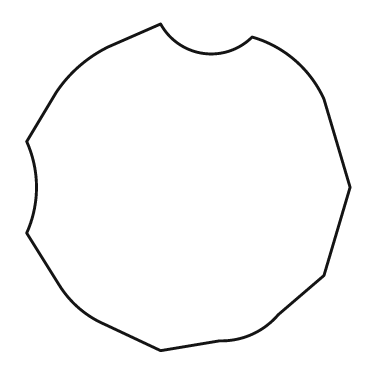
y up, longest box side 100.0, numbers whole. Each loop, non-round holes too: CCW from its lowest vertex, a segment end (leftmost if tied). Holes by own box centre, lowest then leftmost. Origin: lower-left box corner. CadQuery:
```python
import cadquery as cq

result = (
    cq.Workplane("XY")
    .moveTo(41.0, 0.0)
    .lineTo(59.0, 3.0)
    .threePointArc((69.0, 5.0), (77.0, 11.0))
    .lineTo(91.0, 23.0)
    .lineTo(99.0, 50.0)
    .lineTo(91.0, 77.0)
    .threePointArc((82.0, 89.0), (69.0, 96.0))
    .threePointArc((54.0, 91.0), (41.0, 100.0))
    .lineTo(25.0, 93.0)
    .threePointArc((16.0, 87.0), (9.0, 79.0))
    .lineTo(0.0, 64.0)
    .threePointArc((3.0, 50.0), (0.0, 36.0))
    .lineTo(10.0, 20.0)
    .threePointArc((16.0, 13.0), (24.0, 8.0))
    .close()
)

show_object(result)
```